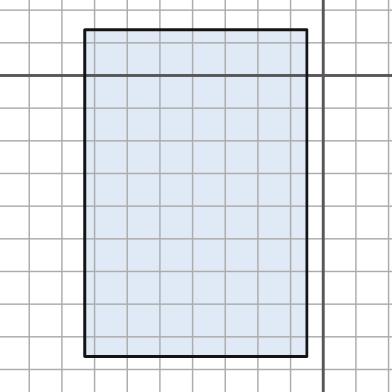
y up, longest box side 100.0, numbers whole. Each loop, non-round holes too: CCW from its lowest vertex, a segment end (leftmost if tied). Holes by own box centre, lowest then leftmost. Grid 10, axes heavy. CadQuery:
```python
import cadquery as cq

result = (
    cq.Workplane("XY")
    .moveTo(-73.0, -86.0)
    .lineTo(-5.0, -86.0)
    .lineTo(-5.0, 14.0)
    .lineTo(-73.0, 14.0)
    .close()
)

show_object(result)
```